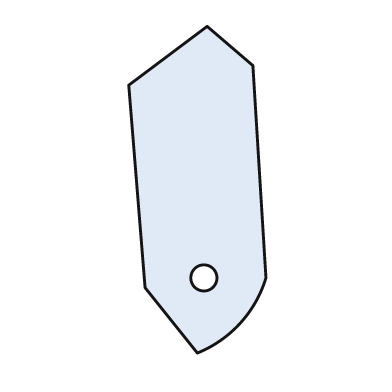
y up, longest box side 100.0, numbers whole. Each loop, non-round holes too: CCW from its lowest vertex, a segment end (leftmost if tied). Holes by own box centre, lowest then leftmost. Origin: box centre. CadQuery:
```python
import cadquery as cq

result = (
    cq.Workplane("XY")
    .moveTo(0.0, -50.0)
    .threePointArc((13.0, -41.0), (21.0, -27.0))
    .lineTo(17.0, 38.0)
    .lineTo(3.0, 50.0)
    .lineTo(-21.0, 32.0)
    .lineTo(-16.0, -30.0)
    .close()
    .moveTo(2.0, -27.0)
    .circle(4.0)
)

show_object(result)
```